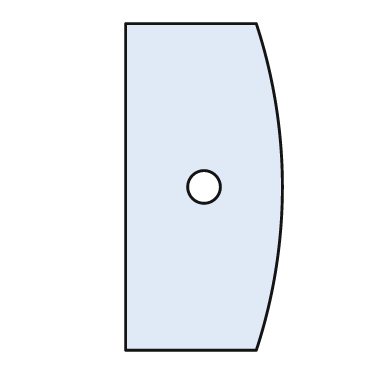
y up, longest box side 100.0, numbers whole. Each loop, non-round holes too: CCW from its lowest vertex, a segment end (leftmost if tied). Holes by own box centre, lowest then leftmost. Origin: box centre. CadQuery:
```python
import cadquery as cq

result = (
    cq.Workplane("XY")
    .moveTo(-24.0, -50.0)
    .lineTo(16.0, -50.0)
    .threePointArc((24.0, 0.0), (16.0, 50.0))
    .lineTo(-24.0, 50.0)
    .close()
    .moveTo(0.0, 0.0)
    .circle(5.0)
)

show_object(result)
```